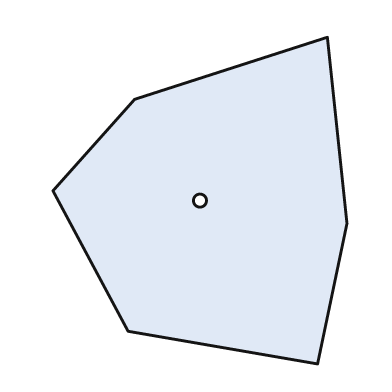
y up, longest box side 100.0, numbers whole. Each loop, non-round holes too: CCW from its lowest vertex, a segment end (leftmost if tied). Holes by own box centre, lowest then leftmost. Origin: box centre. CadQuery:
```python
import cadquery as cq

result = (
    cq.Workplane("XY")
    .moveTo(36.0, -50.0)
    .lineTo(45.0, -7.0)
    .lineTo(39.0, 50.0)
    .lineTo(-20.0, 31.0)
    .lineTo(-45.0, 3.0)
    .lineTo(-22.0, -40.0)
    .close()
    .moveTo(0.0, 0.0)
    .circle(2.0)
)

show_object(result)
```